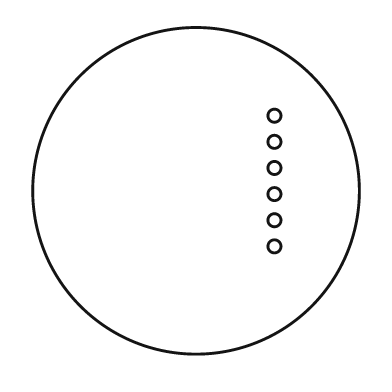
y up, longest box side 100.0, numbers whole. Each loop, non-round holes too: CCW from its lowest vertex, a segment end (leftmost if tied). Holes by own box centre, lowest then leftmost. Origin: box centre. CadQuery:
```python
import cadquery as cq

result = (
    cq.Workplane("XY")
    .moveTo(0.0, 0.0)
    .circle(50.0)
    .moveTo(24.0, -17.0)
    .circle(2.0)
    .moveTo(24.0, -9.0)
    .circle(2.0)
    .moveTo(24.0, -1.0)
    .circle(2.0)
    .moveTo(24.0, 7.0)
    .circle(2.0)
    .moveTo(24.0, 15.0)
    .circle(2.0)
    .moveTo(24.0, 23.0)
    .circle(2.0)
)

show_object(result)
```